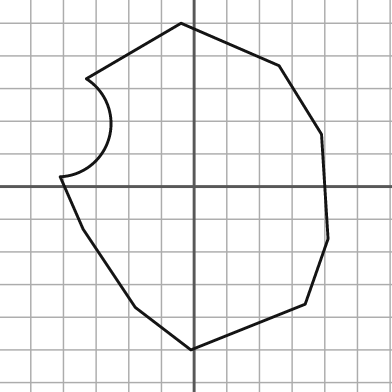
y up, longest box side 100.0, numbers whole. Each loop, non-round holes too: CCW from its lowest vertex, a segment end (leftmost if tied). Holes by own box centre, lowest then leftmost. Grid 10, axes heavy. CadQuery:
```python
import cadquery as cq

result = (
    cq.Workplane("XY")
    .moveTo(-1.0, -50.0)
    .lineTo(34.0, -36.0)
    .lineTo(41.0, -16.0)
    .lineTo(39.0, 16.0)
    .lineTo(26.0, 37.0)
    .lineTo(-4.0, 50.0)
    .lineTo(-33.0, 33.0)
    .threePointArc((-26.0, 15.0), (-41.0, 3.0))
    .lineTo(-34.0, -13.0)
    .lineTo(-18.0, -37.0)
    .close()
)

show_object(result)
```